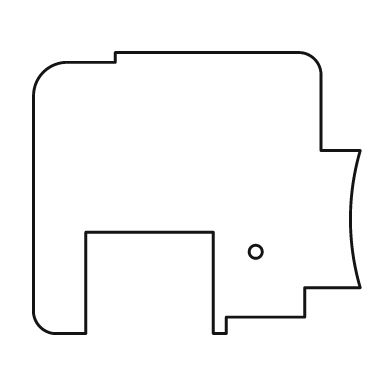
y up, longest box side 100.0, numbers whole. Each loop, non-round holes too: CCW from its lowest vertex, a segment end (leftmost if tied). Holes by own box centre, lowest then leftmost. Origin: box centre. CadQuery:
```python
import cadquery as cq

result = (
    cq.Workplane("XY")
    .moveTo(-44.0, -43.0)
    .lineTo(-34.0, -43.0)
    .lineTo(-34.0, -12.0)
    .lineTo(5.0, -12.0)
    .lineTo(5.0, -43.0)
    .lineTo(9.0, -43.0)
    .lineTo(9.0, -38.0)
    .lineTo(33.0, -38.0)
    .lineTo(33.0, -29.0)
    .lineTo(50.0, -29.0)
    .threePointArc((47.0, -8.0), (50.0, 13.0))
    .lineTo(38.0, 13.0)
    .lineTo(38.0, 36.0)
    .threePointArc((36.0, 41.0), (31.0, 43.0))
    .lineTo(-25.0, 43.0)
    .lineTo(-25.0, 40.0)
    .lineTo(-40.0, 40.0)
    .threePointArc((-47.0, 37.0), (-50.0, 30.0))
    .lineTo(-50.0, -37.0)
    .threePointArc((-48.0, -41.0), (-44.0, -43.0))
    .close()
    .moveTo(18.0, -18.0)
    .circle(2.0)
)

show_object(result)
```